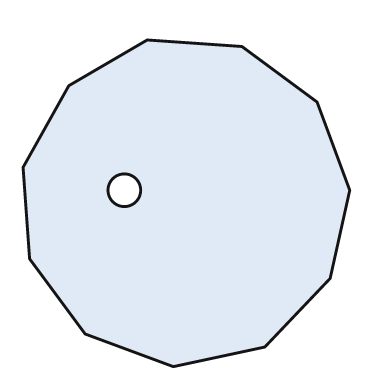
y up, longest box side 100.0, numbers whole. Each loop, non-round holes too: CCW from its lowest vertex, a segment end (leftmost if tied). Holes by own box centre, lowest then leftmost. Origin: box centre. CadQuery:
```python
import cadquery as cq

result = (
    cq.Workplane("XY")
    .moveTo(-4.0, -50.0)
    .lineTo(24.0, -44.0)
    .lineTo(44.0, -23.0)
    .lineTo(50.0, 4.0)
    .lineTo(40.0, 31.0)
    .lineTo(17.0, 48.0)
    .lineTo(-12.0, 50.0)
    .lineTo(-36.0, 36.0)
    .lineTo(-50.0, 11.0)
    .lineTo(-48.0, -17.0)
    .lineTo(-31.0, -40.0)
    .close()
    .moveTo(-19.0, 4.0)
    .circle(5.0)
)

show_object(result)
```